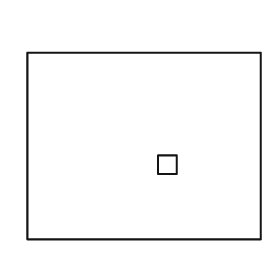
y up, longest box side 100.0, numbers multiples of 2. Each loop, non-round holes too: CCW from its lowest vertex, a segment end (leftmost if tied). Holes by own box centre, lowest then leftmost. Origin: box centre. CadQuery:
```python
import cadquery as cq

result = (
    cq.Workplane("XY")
    .moveTo(-50.0, -40.0)
    .lineTo(50.0, -40.0)
    .lineTo(50.0, 40.0)
    .lineTo(-50.0, 40.0)
    .close()
    .moveTo(6.0, -12.0)
    .lineTo(14.0, -12.0)
    .lineTo(14.0, -4.0)
    .lineTo(6.0, -4.0)
    .close()
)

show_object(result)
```